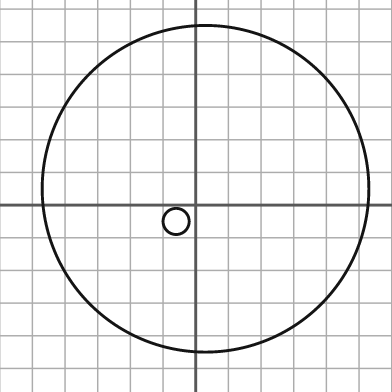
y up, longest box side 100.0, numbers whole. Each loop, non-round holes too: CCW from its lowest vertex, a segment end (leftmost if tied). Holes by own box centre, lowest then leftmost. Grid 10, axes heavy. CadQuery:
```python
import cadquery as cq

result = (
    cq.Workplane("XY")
    .moveTo(3.0, 5.0)
    .circle(50.0)
    .moveTo(-6.0, -5.0)
    .circle(4.0)
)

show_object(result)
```